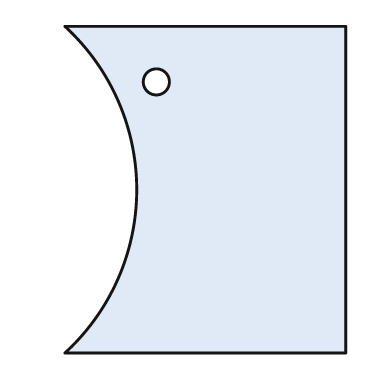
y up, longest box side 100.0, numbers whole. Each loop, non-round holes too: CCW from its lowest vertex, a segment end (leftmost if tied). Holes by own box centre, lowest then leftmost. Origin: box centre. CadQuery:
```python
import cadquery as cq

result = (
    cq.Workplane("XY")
    .moveTo(-43.0, -50.0)
    .lineTo(43.0, -50.0)
    .lineTo(43.0, 50.0)
    .lineTo(-43.0, 50.0)
    .threePointArc((-21.0, 0.0), (-43.0, -50.0))
    .close()
    .moveTo(-15.0, 33.0)
    .circle(4.0)
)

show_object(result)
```